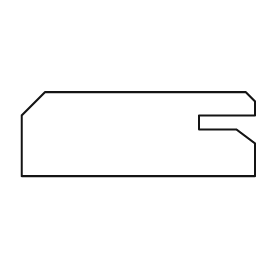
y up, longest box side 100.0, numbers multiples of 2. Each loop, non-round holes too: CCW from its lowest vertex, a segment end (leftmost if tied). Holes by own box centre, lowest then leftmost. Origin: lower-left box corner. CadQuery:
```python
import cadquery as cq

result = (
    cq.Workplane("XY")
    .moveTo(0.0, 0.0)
    .lineTo(100.0, 0.0)
    .lineTo(100.0, 14.0)
    .lineTo(92.0, 20.0)
    .lineTo(76.0, 20.0)
    .lineTo(76.0, 26.0)
    .lineTo(100.0, 26.0)
    .lineTo(100.0, 32.0)
    .lineTo(96.0, 36.0)
    .lineTo(10.0, 36.0)
    .lineTo(0.0, 26.0)
    .close()
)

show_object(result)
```